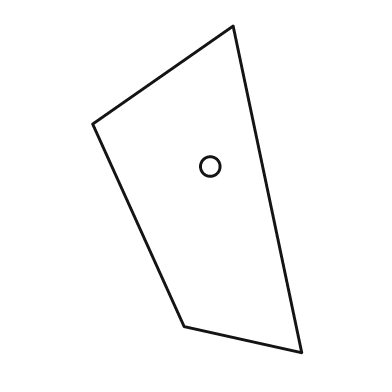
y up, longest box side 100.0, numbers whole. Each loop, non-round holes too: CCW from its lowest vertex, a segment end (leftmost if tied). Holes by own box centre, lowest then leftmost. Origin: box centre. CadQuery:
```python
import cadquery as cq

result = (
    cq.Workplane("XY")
    .moveTo(32.0, -50.0)
    .lineTo(11.0, 50.0)
    .lineTo(-32.0, 20.0)
    .lineTo(-4.0, -42.0)
    .close()
    .moveTo(4.0, 7.0)
    .circle(3.0)
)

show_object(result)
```